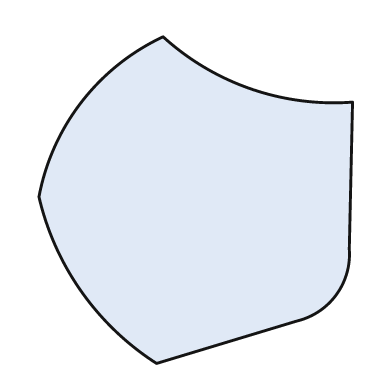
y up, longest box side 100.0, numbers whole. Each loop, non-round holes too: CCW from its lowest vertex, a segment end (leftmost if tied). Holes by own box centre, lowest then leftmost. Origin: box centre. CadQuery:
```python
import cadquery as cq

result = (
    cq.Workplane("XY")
    .moveTo(-12.0, -50.0)
    .lineTo(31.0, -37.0)
    .threePointArc((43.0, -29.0), (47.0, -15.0))
    .lineTo(48.0, 30.0)
    .threePointArc((17.0, 34.0), (-10.0, 50.0))
    .threePointArc((-35.0, 30.0), (-48.0, 1.0))
    .threePointArc((-35.0, -28.0), (-12.0, -50.0))
    .close()
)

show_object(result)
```